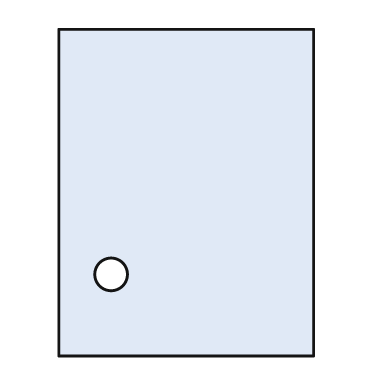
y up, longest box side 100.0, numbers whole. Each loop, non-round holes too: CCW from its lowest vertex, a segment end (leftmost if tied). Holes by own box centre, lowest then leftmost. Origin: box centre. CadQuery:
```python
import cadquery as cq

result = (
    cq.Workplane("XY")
    .moveTo(-39.0, -50.0)
    .lineTo(39.0, -50.0)
    .lineTo(39.0, 50.0)
    .lineTo(-39.0, 50.0)
    .close()
    .moveTo(-23.0, -25.0)
    .circle(5.0)
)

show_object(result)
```